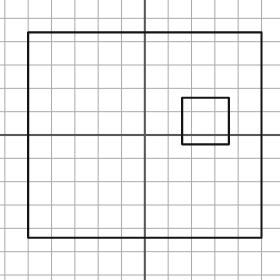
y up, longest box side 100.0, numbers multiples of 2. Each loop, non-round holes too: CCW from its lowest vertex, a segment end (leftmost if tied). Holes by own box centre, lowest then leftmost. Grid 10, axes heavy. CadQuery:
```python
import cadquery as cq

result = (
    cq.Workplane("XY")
    .moveTo(-50.0, -44.0)
    .lineTo(50.0, -44.0)
    .lineTo(50.0, 44.0)
    .lineTo(-50.0, 44.0)
    .close()
    .moveTo(16.0, -4.0)
    .lineTo(36.0, -4.0)
    .lineTo(36.0, 16.0)
    .lineTo(16.0, 16.0)
    .close()
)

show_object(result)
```